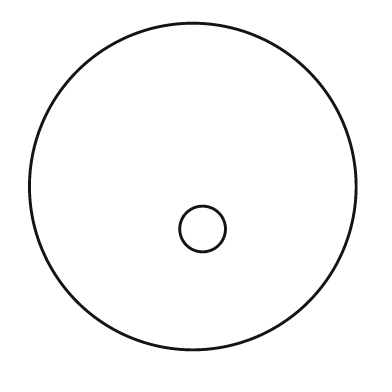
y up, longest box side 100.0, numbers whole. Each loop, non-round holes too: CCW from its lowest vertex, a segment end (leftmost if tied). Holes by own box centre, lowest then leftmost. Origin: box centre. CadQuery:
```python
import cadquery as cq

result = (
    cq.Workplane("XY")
    .moveTo(0.0, 0.0)
    .circle(50.0)
    .moveTo(3.0, -13.0)
    .circle(7.0)
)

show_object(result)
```